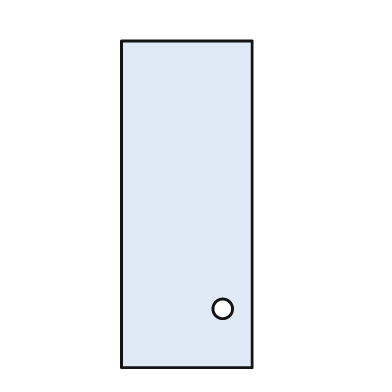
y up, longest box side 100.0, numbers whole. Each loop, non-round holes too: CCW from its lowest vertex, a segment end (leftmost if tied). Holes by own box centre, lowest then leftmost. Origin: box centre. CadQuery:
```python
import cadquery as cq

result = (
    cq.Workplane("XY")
    .moveTo(-20.0, -50.0)
    .lineTo(20.0, -50.0)
    .lineTo(20.0, 50.0)
    .lineTo(-20.0, 50.0)
    .close()
    .moveTo(11.0, -32.0)
    .circle(3.0)
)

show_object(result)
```